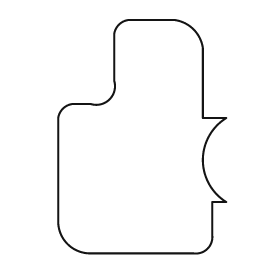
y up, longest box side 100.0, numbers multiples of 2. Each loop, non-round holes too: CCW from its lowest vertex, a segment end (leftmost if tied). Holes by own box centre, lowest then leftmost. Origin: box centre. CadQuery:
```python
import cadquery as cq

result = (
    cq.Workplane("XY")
    .moveTo(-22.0, -50.0)
    .lineTo(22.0, -50.0)
    .threePointArc((28.0, -48.0), (30.0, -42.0))
    .lineTo(30.0, -28.0)
    .lineTo(36.0, -28.0)
    .threePointArc((26.0, -10.0), (36.0, 8.0))
    .lineTo(26.0, 8.0)
    .lineTo(26.0, 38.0)
    .threePointArc((22.0, 46.0), (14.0, 50.0))
    .lineTo(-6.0, 50.0)
    .threePointArc((-10.0, 48.0), (-12.0, 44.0))
    .lineTo(-12.0, 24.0)
    .threePointArc((-14.0, 16.0), (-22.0, 14.0))
    .lineTo(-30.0, 14.0)
    .threePointArc((-34.0, 12.0), (-36.0, 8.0))
    .lineTo(-36.0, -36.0)
    .threePointArc((-32.0, -46.0), (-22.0, -50.0))
    .close()
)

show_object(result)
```